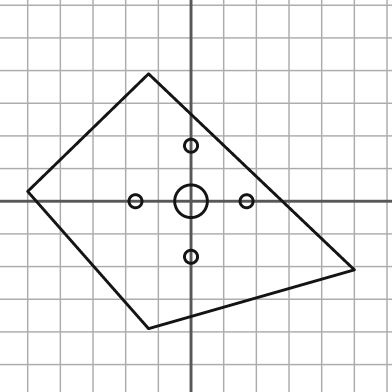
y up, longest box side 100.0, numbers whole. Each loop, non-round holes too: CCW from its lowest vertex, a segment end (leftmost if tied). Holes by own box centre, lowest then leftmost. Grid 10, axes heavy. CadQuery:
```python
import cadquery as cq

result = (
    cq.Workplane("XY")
    .moveTo(-13.0, -39.0)
    .lineTo(50.0, -21.0)
    .lineTo(-13.0, 39.0)
    .lineTo(-50.0, 3.0)
    .close()
    .moveTo(0.0, -17.0)
    .circle(2.0)
    .moveTo(-17.0, 0.0)
    .circle(2.0)
    .moveTo(0.0, 0.0)
    .circle(5.0)
    .moveTo(17.0, 0.0)
    .circle(2.0)
    .moveTo(0.0, 17.0)
    .circle(2.0)
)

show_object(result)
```